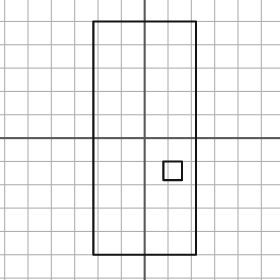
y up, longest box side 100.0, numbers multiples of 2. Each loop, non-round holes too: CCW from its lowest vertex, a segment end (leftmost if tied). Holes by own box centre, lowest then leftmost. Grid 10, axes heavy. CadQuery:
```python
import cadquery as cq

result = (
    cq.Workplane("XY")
    .moveTo(-22.0, -50.0)
    .lineTo(22.0, -50.0)
    .lineTo(22.0, 50.0)
    .lineTo(-22.0, 50.0)
    .close()
    .moveTo(8.0, -18.0)
    .lineTo(16.0, -18.0)
    .lineTo(16.0, -10.0)
    .lineTo(8.0, -10.0)
    .close()
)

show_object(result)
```